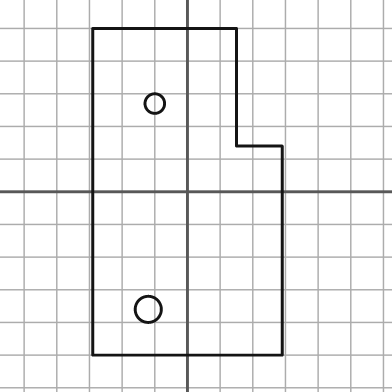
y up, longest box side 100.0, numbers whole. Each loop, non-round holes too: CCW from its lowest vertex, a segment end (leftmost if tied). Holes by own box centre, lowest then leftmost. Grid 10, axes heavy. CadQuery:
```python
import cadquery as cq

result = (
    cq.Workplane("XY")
    .moveTo(-29.0, -50.0)
    .lineTo(29.0, -50.0)
    .lineTo(29.0, 14.0)
    .lineTo(15.0, 14.0)
    .lineTo(15.0, 50.0)
    .lineTo(-29.0, 50.0)
    .close()
    .moveTo(-12.0, -36.0)
    .circle(4.0)
    .moveTo(-10.0, 27.0)
    .circle(3.0)
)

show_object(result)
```